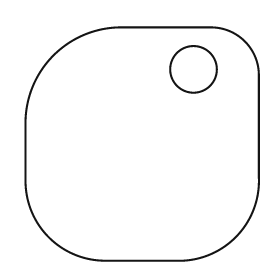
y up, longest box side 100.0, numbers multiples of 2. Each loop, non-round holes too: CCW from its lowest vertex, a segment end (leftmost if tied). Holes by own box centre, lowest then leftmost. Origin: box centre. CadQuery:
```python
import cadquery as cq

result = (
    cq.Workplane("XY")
    .moveTo(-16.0, -50.0)
    .lineTo(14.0, -50.0)
    .threePointArc((40.0, -40.0), (50.0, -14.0))
    .lineTo(50.0, 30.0)
    .threePointArc((44.0, 44.0), (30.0, 50.0))
    .lineTo(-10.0, 50.0)
    .threePointArc((-38.0, 38.0), (-50.0, 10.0))
    .lineTo(-50.0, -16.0)
    .threePointArc((-40.0, -40.0), (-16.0, -50.0))
    .close()
    .moveTo(22.0, 32.0)
    .circle(10.0)
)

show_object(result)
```